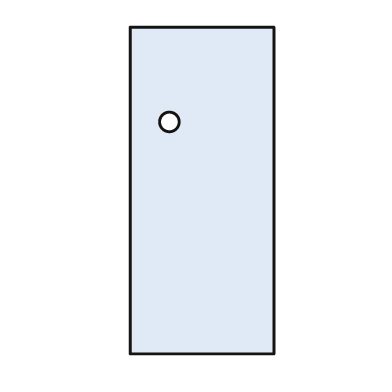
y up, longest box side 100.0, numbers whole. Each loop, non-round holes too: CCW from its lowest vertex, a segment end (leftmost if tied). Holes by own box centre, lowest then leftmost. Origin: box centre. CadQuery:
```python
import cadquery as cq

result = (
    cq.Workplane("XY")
    .moveTo(-22.0, -50.0)
    .lineTo(22.0, -50.0)
    .lineTo(22.0, 50.0)
    .lineTo(-22.0, 50.0)
    .close()
    .moveTo(-10.0, 21.0)
    .circle(3.0)
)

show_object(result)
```